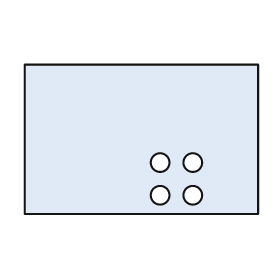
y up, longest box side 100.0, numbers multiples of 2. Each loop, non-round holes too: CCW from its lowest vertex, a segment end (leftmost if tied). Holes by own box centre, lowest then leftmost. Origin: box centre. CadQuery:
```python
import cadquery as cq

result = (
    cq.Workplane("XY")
    .moveTo(-50.0, -32.0)
    .lineTo(50.0, -32.0)
    .lineTo(50.0, 32.0)
    .lineTo(-50.0, 32.0)
    .close()
    .moveTo(8.0, -24.0)
    .circle(4.0)
    .moveTo(22.0, -24.0)
    .circle(4.0)
    .moveTo(8.0, -10.0)
    .circle(4.0)
    .moveTo(22.0, -10.0)
    .circle(4.0)
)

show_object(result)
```